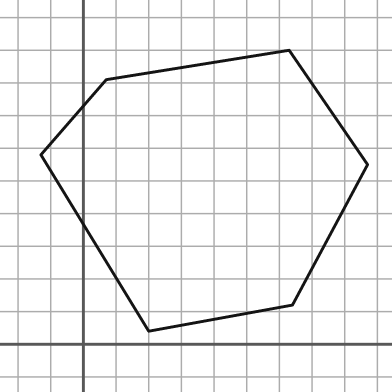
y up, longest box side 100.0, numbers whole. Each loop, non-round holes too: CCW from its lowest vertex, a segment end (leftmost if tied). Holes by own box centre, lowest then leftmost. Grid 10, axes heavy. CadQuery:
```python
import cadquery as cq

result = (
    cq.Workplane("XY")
    .moveTo(20.0, 4.0)
    .lineTo(64.0, 12.0)
    .lineTo(87.0, 55.0)
    .lineTo(63.0, 90.0)
    .lineTo(7.0, 81.0)
    .lineTo(-13.0, 58.0)
    .close()
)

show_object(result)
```